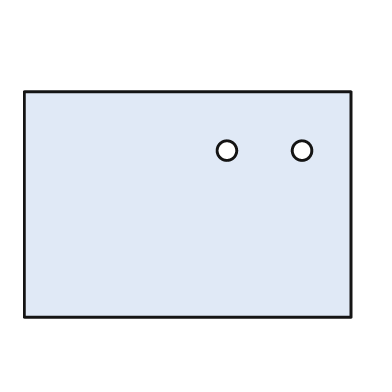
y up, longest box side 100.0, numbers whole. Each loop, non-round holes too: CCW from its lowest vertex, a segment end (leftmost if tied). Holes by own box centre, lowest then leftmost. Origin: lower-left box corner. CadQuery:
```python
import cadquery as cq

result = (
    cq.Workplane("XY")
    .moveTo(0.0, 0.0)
    .lineTo(100.0, 0.0)
    .lineTo(100.0, 69.0)
    .lineTo(0.0, 69.0)
    .close()
    .moveTo(62.0, 51.0)
    .circle(3.0)
    .moveTo(85.0, 51.0)
    .circle(3.0)
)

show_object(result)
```